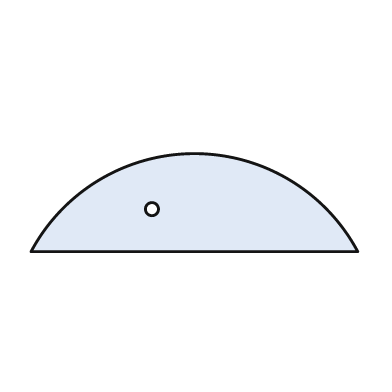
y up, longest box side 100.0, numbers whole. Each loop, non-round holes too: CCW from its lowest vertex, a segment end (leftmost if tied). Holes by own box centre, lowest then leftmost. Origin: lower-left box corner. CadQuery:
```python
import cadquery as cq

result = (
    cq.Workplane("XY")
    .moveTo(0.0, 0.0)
    .lineTo(100.0, 0.0)
    .threePointArc((50.0, 30.0), (0.0, 0.0))
    .close()
    .moveTo(37.0, 13.0)
    .circle(2.0)
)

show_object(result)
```